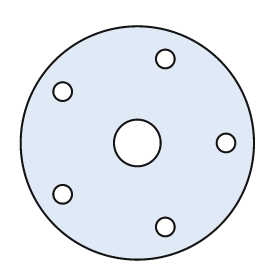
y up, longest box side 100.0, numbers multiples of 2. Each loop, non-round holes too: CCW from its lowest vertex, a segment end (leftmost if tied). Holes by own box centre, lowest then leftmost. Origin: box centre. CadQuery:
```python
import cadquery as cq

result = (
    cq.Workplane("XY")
    .moveTo(0.0, 0.0)
    .circle(50.0)
    .moveTo(12.0, -36.0)
    .circle(4.0)
    .moveTo(-32.0, -22.0)
    .circle(4.0)
    .moveTo(0.0, 0.0)
    .circle(10.0)
    .moveTo(38.0, 0.0)
    .circle(4.0)
    .moveTo(-32.0, 22.0)
    .circle(4.0)
    .moveTo(12.0, 36.0)
    .circle(4.0)
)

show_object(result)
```